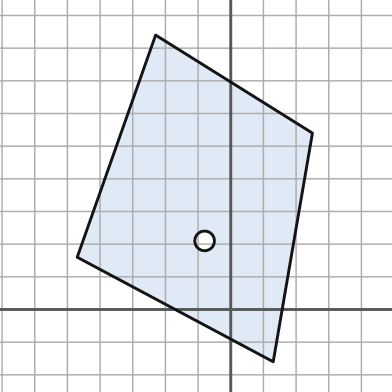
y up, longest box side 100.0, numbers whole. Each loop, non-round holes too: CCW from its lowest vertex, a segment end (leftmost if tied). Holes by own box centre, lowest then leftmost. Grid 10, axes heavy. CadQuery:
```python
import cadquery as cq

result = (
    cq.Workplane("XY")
    .moveTo(13.0, -16.0)
    .lineTo(25.0, 54.0)
    .lineTo(-23.0, 84.0)
    .lineTo(-47.0, 16.0)
    .close()
    .moveTo(-8.0, 21.0)
    .circle(3.0)
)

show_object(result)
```